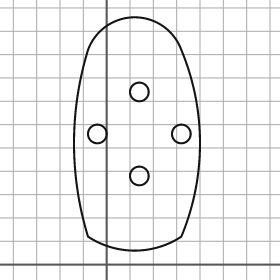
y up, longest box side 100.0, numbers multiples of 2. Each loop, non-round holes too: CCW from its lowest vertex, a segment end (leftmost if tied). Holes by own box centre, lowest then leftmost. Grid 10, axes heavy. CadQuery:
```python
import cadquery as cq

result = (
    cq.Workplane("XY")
    .moveTo(-8.0, 12.0)
    .threePointArc((12.0, 6.0), (32.0, 12.0))
    .threePointArc((40.0, 52.0), (32.0, 92.0))
    .threePointArc((12.0, 106.0), (-8.0, 92.0))
    .threePointArc((-14.0, 52.0), (-8.0, 12.0))
    .close()
    .moveTo(14.0, 38.0)
    .circle(4.0)
    .moveTo(-4.0, 56.0)
    .circle(4.0)
    .moveTo(32.0, 56.0)
    .circle(4.0)
    .moveTo(14.0, 74.0)
    .circle(4.0)
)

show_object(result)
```